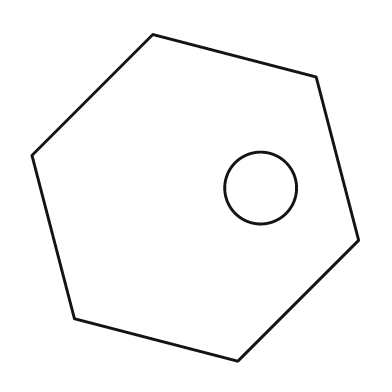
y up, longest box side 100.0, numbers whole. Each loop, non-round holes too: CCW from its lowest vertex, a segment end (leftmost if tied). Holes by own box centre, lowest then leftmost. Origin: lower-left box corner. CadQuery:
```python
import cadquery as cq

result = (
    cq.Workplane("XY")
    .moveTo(63.0, 0.0)
    .lineTo(100.0, 37.0)
    .lineTo(87.0, 87.0)
    .lineTo(37.0, 100.0)
    .lineTo(0.0, 63.0)
    .lineTo(13.0, 13.0)
    .close()
    .moveTo(70.0, 53.0)
    .circle(11.0)
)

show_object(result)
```